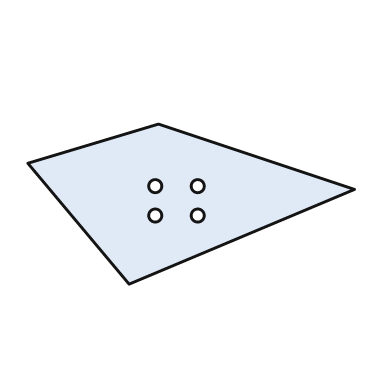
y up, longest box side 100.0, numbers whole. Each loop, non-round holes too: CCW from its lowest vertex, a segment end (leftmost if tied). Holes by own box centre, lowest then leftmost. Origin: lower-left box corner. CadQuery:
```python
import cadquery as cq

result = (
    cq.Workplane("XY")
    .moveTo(31.0, 0.0)
    .lineTo(100.0, 29.0)
    .lineTo(40.0, 49.0)
    .lineTo(0.0, 37.0)
    .close()
    .moveTo(39.0, 21.0)
    .circle(2.0)
    .moveTo(52.0, 21.0)
    .circle(2.0)
    .moveTo(39.0, 30.0)
    .circle(2.0)
    .moveTo(52.0, 30.0)
    .circle(2.0)
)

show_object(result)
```